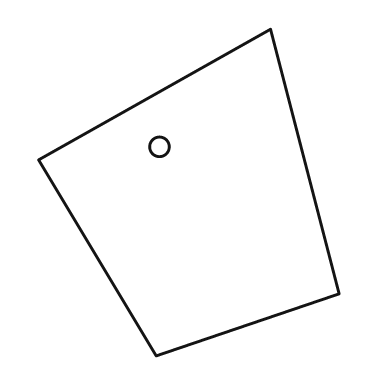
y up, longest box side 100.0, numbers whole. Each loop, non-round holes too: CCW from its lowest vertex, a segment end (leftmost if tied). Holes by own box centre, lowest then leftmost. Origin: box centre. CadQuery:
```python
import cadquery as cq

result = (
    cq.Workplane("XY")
    .moveTo(-10.0, -50.0)
    .lineTo(46.0, -31.0)
    .lineTo(25.0, 50.0)
    .lineTo(-46.0, 10.0)
    .close()
    .moveTo(-9.0, 14.0)
    .circle(3.0)
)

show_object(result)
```